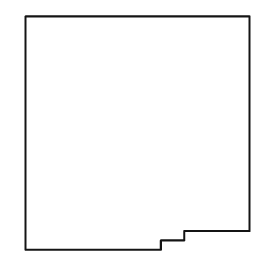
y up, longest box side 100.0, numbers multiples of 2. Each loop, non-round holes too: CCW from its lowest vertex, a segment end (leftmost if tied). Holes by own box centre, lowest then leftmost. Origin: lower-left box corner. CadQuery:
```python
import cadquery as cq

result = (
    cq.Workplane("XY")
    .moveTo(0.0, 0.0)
    .lineTo(58.0, 0.0)
    .lineTo(58.0, 4.0)
    .lineTo(68.0, 4.0)
    .lineTo(68.0, 8.0)
    .lineTo(96.0, 8.0)
    .lineTo(96.0, 100.0)
    .lineTo(0.0, 100.0)
    .close()
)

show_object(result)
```